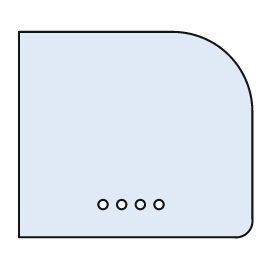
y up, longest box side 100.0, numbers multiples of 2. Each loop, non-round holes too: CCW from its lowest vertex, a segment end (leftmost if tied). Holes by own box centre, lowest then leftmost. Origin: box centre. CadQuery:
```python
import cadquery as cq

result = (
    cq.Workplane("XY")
    .moveTo(-50.0, -44.0)
    .lineTo(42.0, -44.0)
    .threePointArc((48.0, -42.0), (50.0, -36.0))
    .lineTo(50.0, 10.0)
    .threePointArc((40.0, 34.0), (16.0, 44.0))
    .lineTo(-50.0, 44.0)
    .close()
    .moveTo(-14.0, -30.0)
    .circle(2.0)
    .moveTo(-6.0, -30.0)
    .circle(2.0)
    .moveTo(2.0, -30.0)
    .circle(2.0)
    .moveTo(10.0, -30.0)
    .circle(2.0)
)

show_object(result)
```